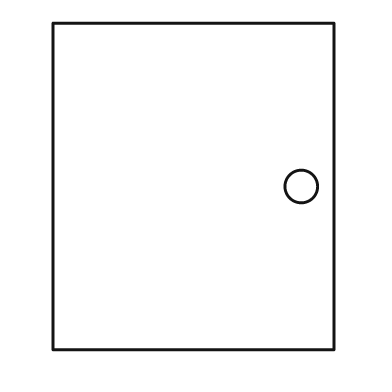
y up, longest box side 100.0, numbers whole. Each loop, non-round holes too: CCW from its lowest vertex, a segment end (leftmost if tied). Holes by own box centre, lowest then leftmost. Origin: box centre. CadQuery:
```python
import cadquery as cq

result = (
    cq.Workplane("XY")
    .moveTo(-43.0, -50.0)
    .lineTo(43.0, -50.0)
    .lineTo(43.0, 50.0)
    .lineTo(-43.0, 50.0)
    .close()
    .moveTo(33.0, 0.0)
    .circle(5.0)
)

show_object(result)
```